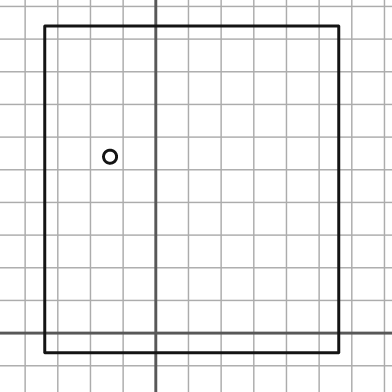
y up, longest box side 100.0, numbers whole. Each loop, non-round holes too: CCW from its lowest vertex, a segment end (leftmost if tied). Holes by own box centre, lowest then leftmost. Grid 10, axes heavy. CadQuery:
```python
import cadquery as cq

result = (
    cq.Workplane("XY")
    .moveTo(-34.0, -6.0)
    .lineTo(56.0, -6.0)
    .lineTo(56.0, 94.0)
    .lineTo(-34.0, 94.0)
    .close()
    .moveTo(-14.0, 54.0)
    .circle(2.0)
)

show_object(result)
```